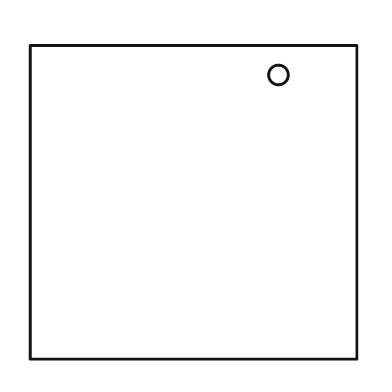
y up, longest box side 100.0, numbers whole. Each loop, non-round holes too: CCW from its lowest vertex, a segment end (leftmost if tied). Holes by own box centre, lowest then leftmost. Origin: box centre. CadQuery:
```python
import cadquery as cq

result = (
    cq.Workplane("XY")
    .moveTo(-50.0, -48.0)
    .lineTo(50.0, -48.0)
    .lineTo(50.0, 48.0)
    .lineTo(-50.0, 48.0)
    .close()
    .moveTo(26.0, 39.0)
    .circle(3.0)
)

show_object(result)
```